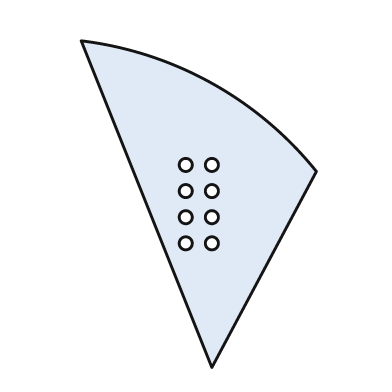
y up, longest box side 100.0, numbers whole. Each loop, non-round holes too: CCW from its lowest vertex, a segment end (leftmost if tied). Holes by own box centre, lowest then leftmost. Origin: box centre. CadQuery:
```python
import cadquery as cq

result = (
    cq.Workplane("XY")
    .moveTo(4.0, -50.0)
    .lineTo(36.0, 10.0)
    .threePointArc((4.0, 37.0), (-36.0, 50.0))
    .close()
    .moveTo(-4.0, -12.0)
    .circle(2.0)
    .moveTo(4.0, -12.0)
    .circle(2.0)
    .moveTo(-4.0, -4.0)
    .circle(2.0)
    .moveTo(4.0, -4.0)
    .circle(2.0)
    .moveTo(-4.0, 4.0)
    .circle(2.0)
    .moveTo(4.0, 4.0)
    .circle(2.0)
    .moveTo(-4.0, 12.0)
    .circle(2.0)
    .moveTo(4.0, 12.0)
    .circle(2.0)
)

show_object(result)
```